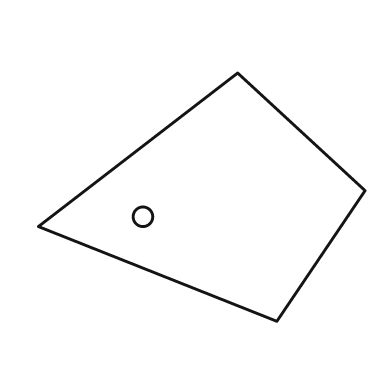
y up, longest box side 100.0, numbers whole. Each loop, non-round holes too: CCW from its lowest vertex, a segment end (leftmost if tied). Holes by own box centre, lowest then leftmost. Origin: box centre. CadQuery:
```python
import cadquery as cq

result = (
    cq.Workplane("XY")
    .moveTo(23.0, -38.0)
    .lineTo(50.0, 2.0)
    .lineTo(11.0, 38.0)
    .lineTo(-50.0, -9.0)
    .close()
    .moveTo(-18.0, -6.0)
    .circle(3.0)
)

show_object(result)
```